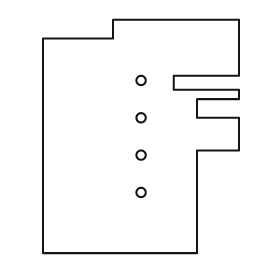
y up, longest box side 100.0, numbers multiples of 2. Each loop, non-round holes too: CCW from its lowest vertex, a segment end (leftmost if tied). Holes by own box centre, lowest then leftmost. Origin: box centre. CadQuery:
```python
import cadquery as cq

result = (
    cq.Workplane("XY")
    .moveTo(-42.0, -50.0)
    .lineTo(24.0, -50.0)
    .lineTo(24.0, -6.0)
    .lineTo(42.0, -6.0)
    .lineTo(42.0, 8.0)
    .lineTo(24.0, 8.0)
    .lineTo(24.0, 16.0)
    .lineTo(42.0, 16.0)
    .lineTo(42.0, 20.0)
    .lineTo(14.0, 20.0)
    .lineTo(14.0, 26.0)
    .lineTo(42.0, 26.0)
    .lineTo(42.0, 50.0)
    .lineTo(-12.0, 50.0)
    .lineTo(-12.0, 42.0)
    .lineTo(-42.0, 42.0)
    .close()
    .moveTo(0.0, -24.0)
    .circle(2.0)
    .moveTo(0.0, -8.0)
    .circle(2.0)
    .moveTo(0.0, 8.0)
    .circle(2.0)
    .moveTo(0.0, 24.0)
    .circle(2.0)
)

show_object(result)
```